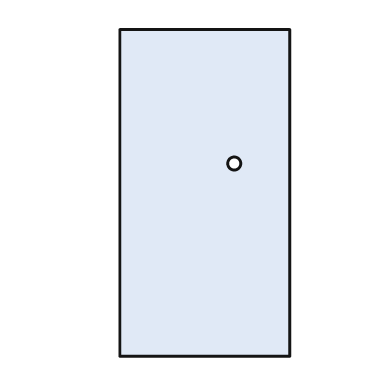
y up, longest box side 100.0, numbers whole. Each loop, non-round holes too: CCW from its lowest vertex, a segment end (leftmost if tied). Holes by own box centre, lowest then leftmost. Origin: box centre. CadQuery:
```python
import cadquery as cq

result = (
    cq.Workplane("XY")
    .moveTo(-26.0, -50.0)
    .lineTo(26.0, -50.0)
    .lineTo(26.0, 50.0)
    .lineTo(-26.0, 50.0)
    .close()
    .moveTo(9.0, 9.0)
    .circle(2.0)
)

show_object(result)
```